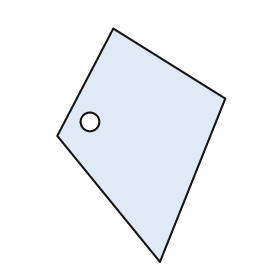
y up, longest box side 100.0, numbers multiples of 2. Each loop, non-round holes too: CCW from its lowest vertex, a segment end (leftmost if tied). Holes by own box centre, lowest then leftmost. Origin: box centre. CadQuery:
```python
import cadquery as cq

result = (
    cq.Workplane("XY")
    .moveTo(8.0, -50.0)
    .lineTo(36.0, 20.0)
    .lineTo(-12.0, 50.0)
    .lineTo(-36.0, 4.0)
    .close()
    .moveTo(-22.0, 10.0)
    .circle(4.0)
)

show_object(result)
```